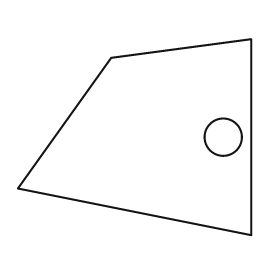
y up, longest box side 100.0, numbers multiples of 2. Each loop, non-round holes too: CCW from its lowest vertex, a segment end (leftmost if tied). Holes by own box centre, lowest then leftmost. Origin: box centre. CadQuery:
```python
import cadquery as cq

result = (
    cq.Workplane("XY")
    .moveTo(50.0, -42.0)
    .lineTo(50.0, 42.0)
    .lineTo(-10.0, 34.0)
    .lineTo(-50.0, -22.0)
    .close()
    .moveTo(38.0, 0.0)
    .circle(8.0)
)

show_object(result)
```